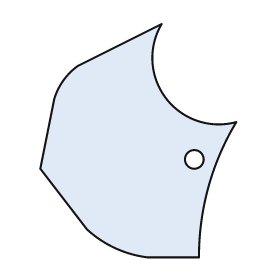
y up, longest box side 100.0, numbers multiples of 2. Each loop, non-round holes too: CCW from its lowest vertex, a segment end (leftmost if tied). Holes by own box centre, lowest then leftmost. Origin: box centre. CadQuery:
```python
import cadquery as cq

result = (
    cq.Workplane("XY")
    .moveTo(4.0, -50.0)
    .lineTo(26.0, -50.0)
    .threePointArc((30.0, -20.0), (42.0, 8.0))
    .threePointArc((12.0, 18.0), (10.0, 50.0))
    .lineTo(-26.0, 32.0)
    .threePointArc((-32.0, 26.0), (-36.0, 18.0))
    .lineTo(-42.0, -12.0)
    .lineTo(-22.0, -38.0)
    .threePointArc((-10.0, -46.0), (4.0, -50.0))
    .close()
    .moveTo(24.0, -8.0)
    .circle(4.0)
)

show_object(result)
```